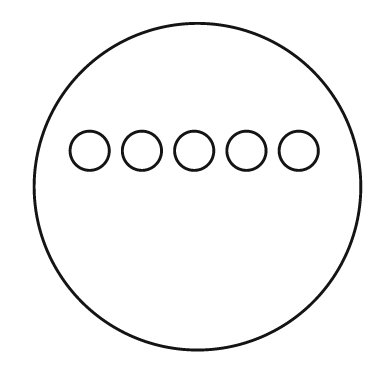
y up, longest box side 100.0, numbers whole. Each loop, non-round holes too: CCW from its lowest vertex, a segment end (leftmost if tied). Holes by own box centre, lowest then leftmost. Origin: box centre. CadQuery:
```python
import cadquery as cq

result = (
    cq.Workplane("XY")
    .moveTo(0.0, 0.0)
    .circle(50.0)
    .moveTo(-33.0, 11.0)
    .circle(6.0)
    .moveTo(-17.0, 11.0)
    .circle(6.0)
    .moveTo(-1.0, 11.0)
    .circle(6.0)
    .moveTo(15.0, 11.0)
    .circle(6.0)
    .moveTo(31.0, 11.0)
    .circle(6.0)
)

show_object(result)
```